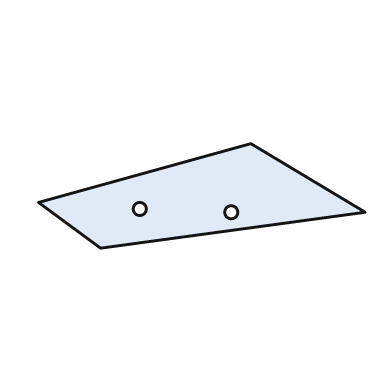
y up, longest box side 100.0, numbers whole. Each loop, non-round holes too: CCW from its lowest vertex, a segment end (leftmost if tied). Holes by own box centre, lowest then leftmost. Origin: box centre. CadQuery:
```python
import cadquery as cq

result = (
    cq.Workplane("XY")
    .moveTo(-31.0, -16.0)
    .lineTo(50.0, -5.0)
    .lineTo(15.0, 16.0)
    .lineTo(-50.0, -2.0)
    .close()
    .moveTo(9.0, -5.0)
    .circle(2.0)
    .moveTo(-19.0, -4.0)
    .circle(2.0)
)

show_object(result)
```